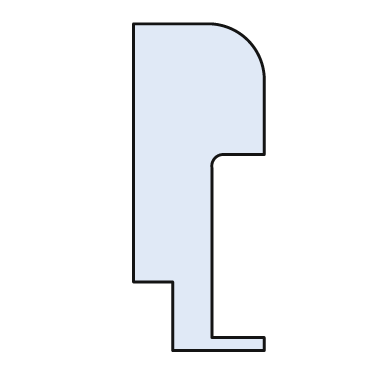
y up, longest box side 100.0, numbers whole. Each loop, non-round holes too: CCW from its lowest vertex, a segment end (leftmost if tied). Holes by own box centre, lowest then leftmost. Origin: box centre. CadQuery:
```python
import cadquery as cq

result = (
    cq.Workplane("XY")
    .moveTo(-8.0, -50.0)
    .lineTo(20.0, -50.0)
    .lineTo(20.0, -46.0)
    .lineTo(4.0, -46.0)
    .lineTo(4.0, 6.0)
    .threePointArc((5.0, 9.0), (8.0, 10.0))
    .lineTo(20.0, 10.0)
    .lineTo(20.0, 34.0)
    .threePointArc((15.0, 45.0), (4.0, 50.0))
    .lineTo(-20.0, 50.0)
    .lineTo(-20.0, -29.0)
    .lineTo(-8.0, -29.0)
    .close()
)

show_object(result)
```